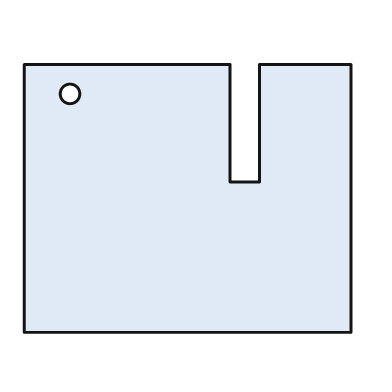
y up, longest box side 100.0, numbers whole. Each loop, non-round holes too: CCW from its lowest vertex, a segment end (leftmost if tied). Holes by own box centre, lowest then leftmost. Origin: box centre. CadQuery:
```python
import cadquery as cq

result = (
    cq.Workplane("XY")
    .moveTo(-50.0, -41.0)
    .lineTo(50.0, -41.0)
    .lineTo(50.0, 41.0)
    .lineTo(22.0, 41.0)
    .lineTo(22.0, 5.0)
    .lineTo(13.0, 5.0)
    .lineTo(13.0, 41.0)
    .lineTo(-50.0, 41.0)
    .close()
    .moveTo(-36.0, 32.0)
    .circle(3.0)
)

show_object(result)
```